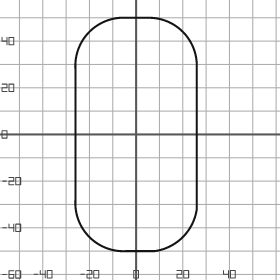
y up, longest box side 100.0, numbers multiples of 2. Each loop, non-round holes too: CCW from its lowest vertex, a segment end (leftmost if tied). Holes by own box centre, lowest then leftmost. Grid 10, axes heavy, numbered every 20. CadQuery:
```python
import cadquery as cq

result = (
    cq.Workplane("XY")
    .moveTo(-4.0, -50.0)
    .lineTo(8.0, -50.0)
    .threePointArc((20.0, -44.0), (26.0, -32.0))
    .lineTo(26.0, 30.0)
    .threePointArc((20.0, 44.0), (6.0, 50.0))
    .lineTo(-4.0, 50.0)
    .threePointArc((-20.0, 44.0), (-26.0, 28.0))
    .lineTo(-26.0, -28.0)
    .threePointArc((-20.0, -44.0), (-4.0, -50.0))
    .close()
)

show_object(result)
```